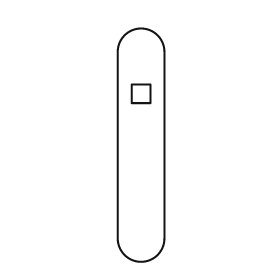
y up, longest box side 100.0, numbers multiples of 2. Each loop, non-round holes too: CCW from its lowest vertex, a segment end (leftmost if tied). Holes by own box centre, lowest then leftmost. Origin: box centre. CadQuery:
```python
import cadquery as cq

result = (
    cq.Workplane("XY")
    .moveTo(-10.0, -40.0)
    .threePointArc((0.0, -50.0), (10.0, -40.0))
    .lineTo(10.0, 40.0)
    .threePointArc((0.0, 50.0), (-10.0, 40.0))
    .close()
    .moveTo(-4.0, 18.0)
    .lineTo(4.0, 18.0)
    .lineTo(4.0, 26.0)
    .lineTo(-4.0, 26.0)
    .close()
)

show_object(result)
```